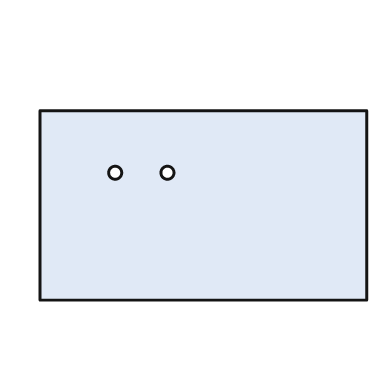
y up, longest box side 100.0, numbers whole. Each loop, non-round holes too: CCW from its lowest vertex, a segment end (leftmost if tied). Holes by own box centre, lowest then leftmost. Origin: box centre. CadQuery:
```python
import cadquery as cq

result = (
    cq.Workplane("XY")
    .moveTo(-50.0, -29.0)
    .lineTo(50.0, -29.0)
    .lineTo(50.0, 29.0)
    .lineTo(-50.0, 29.0)
    .close()
    .moveTo(-27.0, 10.0)
    .circle(2.0)
    .moveTo(-11.0, 10.0)
    .circle(2.0)
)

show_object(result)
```